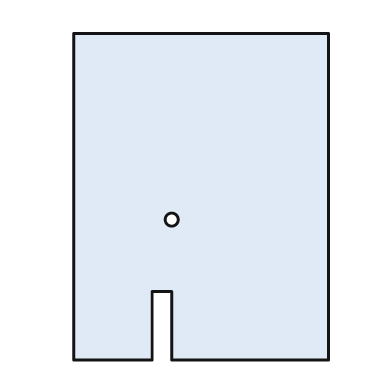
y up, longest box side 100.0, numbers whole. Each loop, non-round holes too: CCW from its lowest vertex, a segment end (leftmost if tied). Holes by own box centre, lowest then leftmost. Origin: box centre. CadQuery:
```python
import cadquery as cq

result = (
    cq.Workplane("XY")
    .moveTo(-39.0, -50.0)
    .lineTo(-15.0, -50.0)
    .lineTo(-15.0, -29.0)
    .lineTo(-9.0, -29.0)
    .lineTo(-9.0, -50.0)
    .lineTo(39.0, -50.0)
    .lineTo(39.0, 50.0)
    .lineTo(-39.0, 50.0)
    .close()
    .moveTo(-9.0, -7.0)
    .circle(2.0)
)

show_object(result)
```